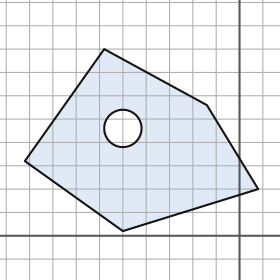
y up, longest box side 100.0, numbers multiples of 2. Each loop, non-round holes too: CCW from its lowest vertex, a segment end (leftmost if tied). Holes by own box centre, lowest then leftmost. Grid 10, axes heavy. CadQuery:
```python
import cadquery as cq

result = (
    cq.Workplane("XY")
    .moveTo(-50.0, 2.0)
    .lineTo(8.0, 20.0)
    .lineTo(-14.0, 56.0)
    .lineTo(-58.0, 80.0)
    .lineTo(-92.0, 32.0)
    .close()
    .moveTo(-50.0, 46.0)
    .circle(8.0)
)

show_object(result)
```